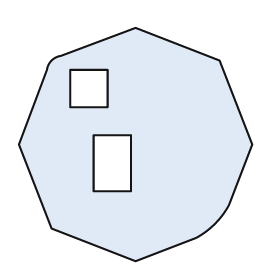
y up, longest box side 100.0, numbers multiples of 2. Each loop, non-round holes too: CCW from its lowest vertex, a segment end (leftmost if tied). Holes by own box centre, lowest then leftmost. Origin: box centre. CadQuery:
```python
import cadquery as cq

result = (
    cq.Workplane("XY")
    .moveTo(0.0, -50.0)
    .lineTo(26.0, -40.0)
    .threePointArc((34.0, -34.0), (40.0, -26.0))
    .lineTo(50.0, 0.0)
    .lineTo(36.0, 36.0)
    .lineTo(0.0, 50.0)
    .lineTo(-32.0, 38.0)
    .threePointArc((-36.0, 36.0), (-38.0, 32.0))
    .lineTo(-50.0, 0.0)
    .lineTo(-36.0, -36.0)
    .close()
    .moveTo(-18.0, -20.0)
    .lineTo(-2.0, -20.0)
    .lineTo(-2.0, 4.0)
    .lineTo(-18.0, 4.0)
    .close()
    .moveTo(-28.0, 16.0)
    .lineTo(-12.0, 16.0)
    .lineTo(-12.0, 32.0)
    .lineTo(-28.0, 32.0)
    .close()
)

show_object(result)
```